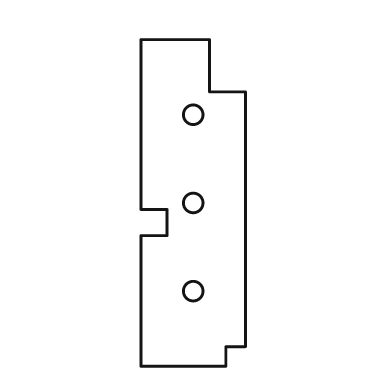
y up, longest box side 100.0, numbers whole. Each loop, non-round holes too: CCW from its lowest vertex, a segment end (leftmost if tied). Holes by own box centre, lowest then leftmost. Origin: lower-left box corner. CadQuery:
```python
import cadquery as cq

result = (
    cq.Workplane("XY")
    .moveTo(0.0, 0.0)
    .lineTo(26.0, 0.0)
    .lineTo(26.0, 6.0)
    .lineTo(32.0, 6.0)
    .lineTo(32.0, 84.0)
    .lineTo(21.0, 84.0)
    .lineTo(21.0, 100.0)
    .lineTo(0.0, 100.0)
    .lineTo(0.0, 48.0)
    .lineTo(8.0, 48.0)
    .lineTo(8.0, 40.0)
    .lineTo(0.0, 40.0)
    .close()
    .moveTo(16.0, 23.0)
    .circle(3.0)
    .moveTo(16.0, 50.0)
    .circle(3.0)
    .moveTo(16.0, 77.0)
    .circle(3.0)
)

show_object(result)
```